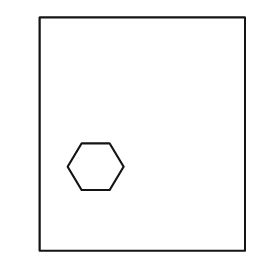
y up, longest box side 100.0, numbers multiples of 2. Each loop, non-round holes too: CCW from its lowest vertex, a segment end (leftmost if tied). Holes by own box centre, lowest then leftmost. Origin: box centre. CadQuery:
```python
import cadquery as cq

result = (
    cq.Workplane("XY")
    .moveTo(-44.0, -50.0)
    .lineTo(44.0, -50.0)
    .lineTo(44.0, 50.0)
    .lineTo(-44.0, 50.0)
    .close()
    .moveTo(-26.0, -24.0)
    .lineTo(-14.0, -24.0)
    .lineTo(-8.0, -14.0)
    .lineTo(-14.0, -4.0)
    .lineTo(-26.0, -4.0)
    .lineTo(-32.0, -14.0)
    .close()
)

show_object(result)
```